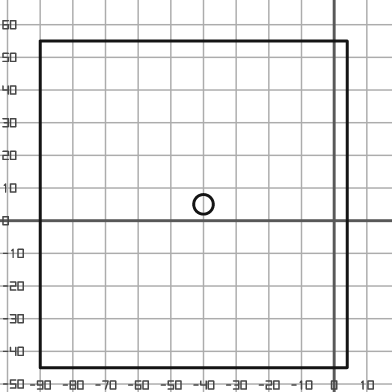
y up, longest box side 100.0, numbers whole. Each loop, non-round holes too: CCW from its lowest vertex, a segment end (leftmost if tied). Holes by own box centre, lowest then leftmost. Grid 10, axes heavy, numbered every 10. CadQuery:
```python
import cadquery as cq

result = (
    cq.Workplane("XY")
    .moveTo(-90.0, -45.0)
    .lineTo(4.0, -45.0)
    .lineTo(4.0, 55.0)
    .lineTo(-90.0, 55.0)
    .close()
    .moveTo(-40.0, 5.0)
    .circle(3.0)
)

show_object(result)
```